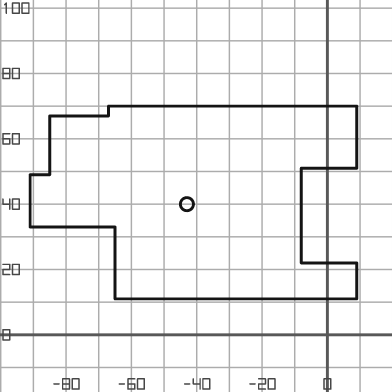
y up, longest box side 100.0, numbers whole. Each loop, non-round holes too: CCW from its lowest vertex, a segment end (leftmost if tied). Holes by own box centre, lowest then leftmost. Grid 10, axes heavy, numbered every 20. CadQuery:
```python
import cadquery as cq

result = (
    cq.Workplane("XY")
    .moveTo(-65.0, 11.0)
    .lineTo(9.0, 11.0)
    .lineTo(9.0, 22.0)
    .lineTo(-8.0, 22.0)
    .lineTo(-8.0, 51.0)
    .lineTo(9.0, 51.0)
    .lineTo(9.0, 70.0)
    .lineTo(-67.0, 70.0)
    .lineTo(-67.0, 67.0)
    .lineTo(-85.0, 67.0)
    .lineTo(-85.0, 49.0)
    .lineTo(-91.0, 49.0)
    .lineTo(-91.0, 33.0)
    .lineTo(-65.0, 33.0)
    .close()
    .moveTo(-43.0, 40.0)
    .circle(2.0)
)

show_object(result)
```